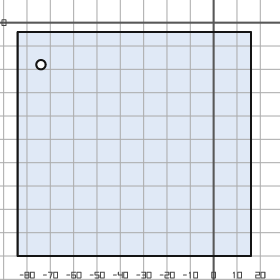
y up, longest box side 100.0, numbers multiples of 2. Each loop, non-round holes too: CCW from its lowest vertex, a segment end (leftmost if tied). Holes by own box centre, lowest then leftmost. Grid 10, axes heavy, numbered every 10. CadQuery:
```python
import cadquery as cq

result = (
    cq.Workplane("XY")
    .moveTo(-84.0, -100.0)
    .lineTo(16.0, -100.0)
    .lineTo(16.0, -4.0)
    .lineTo(-84.0, -4.0)
    .close()
    .moveTo(-74.0, -18.0)
    .circle(2.0)
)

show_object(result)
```